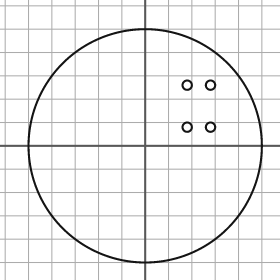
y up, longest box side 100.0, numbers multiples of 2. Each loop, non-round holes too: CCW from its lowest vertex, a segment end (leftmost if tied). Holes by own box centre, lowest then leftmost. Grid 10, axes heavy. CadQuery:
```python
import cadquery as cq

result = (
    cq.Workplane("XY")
    .moveTo(0.0, 0.0)
    .circle(50.0)
    .moveTo(18.0, 8.0)
    .circle(2.0)
    .moveTo(28.0, 8.0)
    .circle(2.0)
    .moveTo(18.0, 26.0)
    .circle(2.0)
    .moveTo(28.0, 26.0)
    .circle(2.0)
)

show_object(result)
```